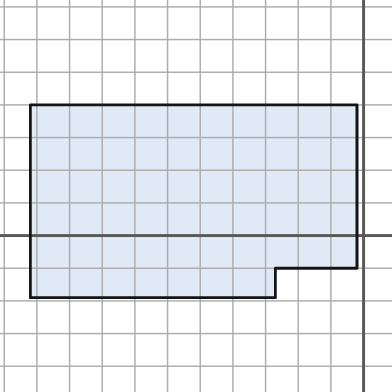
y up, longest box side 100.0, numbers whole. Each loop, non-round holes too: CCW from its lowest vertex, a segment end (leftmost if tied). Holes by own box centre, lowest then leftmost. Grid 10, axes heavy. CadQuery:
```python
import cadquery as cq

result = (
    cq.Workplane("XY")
    .moveTo(-102.0, -19.0)
    .lineTo(-27.0, -19.0)
    .lineTo(-27.0, -10.0)
    .lineTo(-2.0, -10.0)
    .lineTo(-2.0, 40.0)
    .lineTo(-102.0, 40.0)
    .close()
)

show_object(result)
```